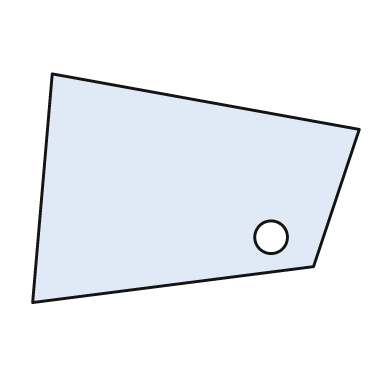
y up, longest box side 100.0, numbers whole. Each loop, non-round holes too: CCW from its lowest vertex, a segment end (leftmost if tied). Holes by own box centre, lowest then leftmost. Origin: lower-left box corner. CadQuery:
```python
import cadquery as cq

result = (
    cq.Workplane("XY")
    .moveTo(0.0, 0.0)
    .lineTo(86.0, 11.0)
    .lineTo(100.0, 53.0)
    .lineTo(6.0, 70.0)
    .close()
    .moveTo(73.0, 20.0)
    .circle(5.0)
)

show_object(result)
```